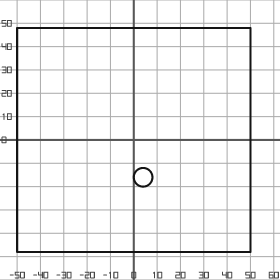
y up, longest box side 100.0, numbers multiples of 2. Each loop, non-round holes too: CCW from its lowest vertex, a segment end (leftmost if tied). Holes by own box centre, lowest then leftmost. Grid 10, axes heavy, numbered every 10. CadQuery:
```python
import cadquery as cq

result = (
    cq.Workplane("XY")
    .moveTo(-50.0, -48.0)
    .lineTo(50.0, -48.0)
    .lineTo(50.0, 48.0)
    .lineTo(-50.0, 48.0)
    .close()
    .moveTo(4.0, -16.0)
    .circle(4.0)
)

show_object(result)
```